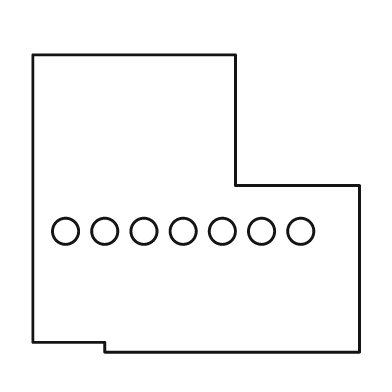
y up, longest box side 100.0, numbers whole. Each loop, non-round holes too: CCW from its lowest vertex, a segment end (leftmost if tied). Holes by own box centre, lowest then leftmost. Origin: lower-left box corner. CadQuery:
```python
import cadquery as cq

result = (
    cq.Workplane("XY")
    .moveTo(22.0, 0.0)
    .lineTo(100.0, 0.0)
    .lineTo(100.0, 51.0)
    .lineTo(62.0, 51.0)
    .lineTo(62.0, 91.0)
    .lineTo(0.0, 91.0)
    .lineTo(0.0, 3.0)
    .lineTo(22.0, 3.0)
    .close()
    .moveTo(10.0, 37.0)
    .circle(4.0)
    .moveTo(22.0, 37.0)
    .circle(4.0)
    .moveTo(34.0, 37.0)
    .circle(4.0)
    .moveTo(46.0, 37.0)
    .circle(4.0)
    .moveTo(58.0, 37.0)
    .circle(4.0)
    .moveTo(70.0, 37.0)
    .circle(4.0)
    .moveTo(82.0, 37.0)
    .circle(4.0)
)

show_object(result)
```